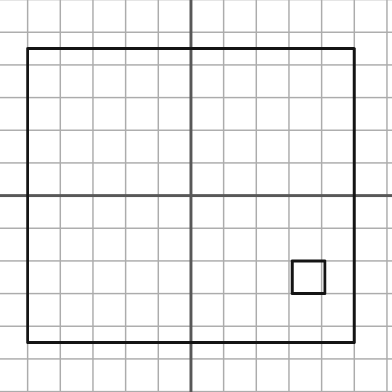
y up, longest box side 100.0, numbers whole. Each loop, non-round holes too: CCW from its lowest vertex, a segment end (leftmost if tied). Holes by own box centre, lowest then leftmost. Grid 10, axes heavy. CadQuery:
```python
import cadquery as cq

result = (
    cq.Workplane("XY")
    .moveTo(-50.0, -45.0)
    .lineTo(50.0, -45.0)
    .lineTo(50.0, 45.0)
    .lineTo(-50.0, 45.0)
    .close()
    .moveTo(31.0, -30.0)
    .lineTo(41.0, -30.0)
    .lineTo(41.0, -20.0)
    .lineTo(31.0, -20.0)
    .close()
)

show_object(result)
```